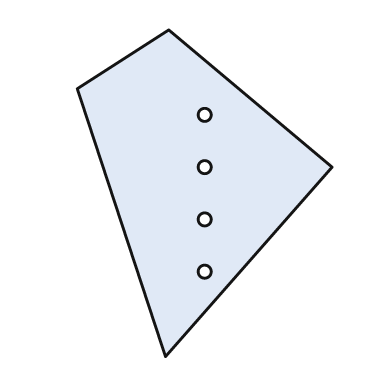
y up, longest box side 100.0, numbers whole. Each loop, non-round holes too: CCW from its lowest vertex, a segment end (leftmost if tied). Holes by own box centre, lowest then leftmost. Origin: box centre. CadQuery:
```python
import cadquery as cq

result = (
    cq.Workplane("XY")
    .moveTo(-12.0, -50.0)
    .lineTo(39.0, 8.0)
    .lineTo(-11.0, 50.0)
    .lineTo(-39.0, 32.0)
    .close()
    .moveTo(0.0, -24.0)
    .circle(2.0)
    .moveTo(0.0, -8.0)
    .circle(2.0)
    .moveTo(0.0, 8.0)
    .circle(2.0)
    .moveTo(0.0, 24.0)
    .circle(2.0)
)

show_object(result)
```